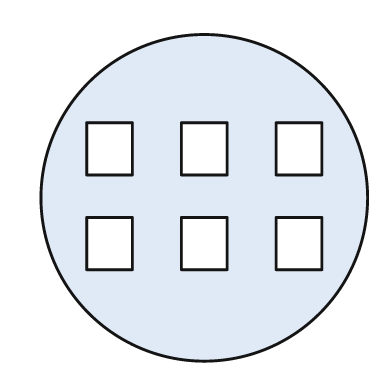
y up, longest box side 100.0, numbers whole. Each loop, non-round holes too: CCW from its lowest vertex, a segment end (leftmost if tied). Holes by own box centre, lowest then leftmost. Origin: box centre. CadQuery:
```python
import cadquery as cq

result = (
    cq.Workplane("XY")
    .moveTo(0.0, 0.0)
    .circle(50.0)
    .moveTo(-36.0, -22.0)
    .lineTo(-22.0, -22.0)
    .lineTo(-22.0, -6.0)
    .lineTo(-36.0, -6.0)
    .close()
    .moveTo(-7.0, -22.0)
    .lineTo(7.0, -22.0)
    .lineTo(7.0, -6.0)
    .lineTo(-7.0, -6.0)
    .close()
    .moveTo(22.0, -22.0)
    .lineTo(36.0, -22.0)
    .lineTo(36.0, -6.0)
    .lineTo(22.0, -6.0)
    .close()
    .moveTo(-36.0, 7.0)
    .lineTo(-22.0, 7.0)
    .lineTo(-22.0, 23.0)
    .lineTo(-36.0, 23.0)
    .close()
    .moveTo(-7.0, 7.0)
    .lineTo(7.0, 7.0)
    .lineTo(7.0, 23.0)
    .lineTo(-7.0, 23.0)
    .close()
    .moveTo(22.0, 7.0)
    .lineTo(36.0, 7.0)
    .lineTo(36.0, 23.0)
    .lineTo(22.0, 23.0)
    .close()
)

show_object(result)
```